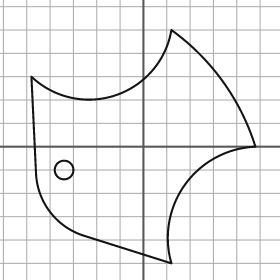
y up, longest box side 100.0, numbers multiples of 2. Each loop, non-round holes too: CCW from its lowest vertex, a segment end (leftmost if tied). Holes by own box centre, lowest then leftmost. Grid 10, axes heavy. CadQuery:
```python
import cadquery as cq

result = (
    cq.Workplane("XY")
    .moveTo(12.0, -50.0)
    .threePointArc((18.0, -16.0), (48.0, 0.0))
    .threePointArc((34.0, 28.0), (12.0, 50.0))
    .threePointArc((-12.0, 22.0), (-48.0, 30.0))
    .lineTo(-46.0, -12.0)
    .threePointArc((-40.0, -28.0), (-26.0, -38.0))
    .close()
    .moveTo(-34.0, -10.0)
    .circle(4.0)
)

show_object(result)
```